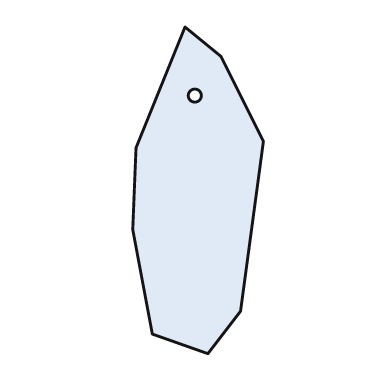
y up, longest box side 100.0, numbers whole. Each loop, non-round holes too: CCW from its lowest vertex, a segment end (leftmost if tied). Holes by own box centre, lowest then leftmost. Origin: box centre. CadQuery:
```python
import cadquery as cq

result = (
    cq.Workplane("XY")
    .moveTo(3.0, -50.0)
    .lineTo(13.0, -37.0)
    .lineTo(20.0, 15.0)
    .lineTo(7.0, 41.0)
    .lineTo(-4.0, 50.0)
    .lineTo(-19.0, 13.0)
    .lineTo(-20.0, -12.0)
    .lineTo(-14.0, -44.0)
    .close()
    .moveTo(-1.0, 29.0)
    .circle(2.0)
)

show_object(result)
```